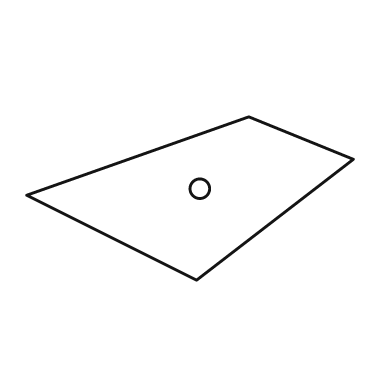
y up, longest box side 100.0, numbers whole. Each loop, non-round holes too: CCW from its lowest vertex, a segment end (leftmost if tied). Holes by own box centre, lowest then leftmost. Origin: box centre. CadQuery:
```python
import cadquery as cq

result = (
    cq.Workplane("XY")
    .moveTo(2.0, -25.0)
    .lineTo(50.0, 12.0)
    .lineTo(18.0, 25.0)
    .lineTo(-50.0, 1.0)
    .close()
    .moveTo(3.0, 3.0)
    .circle(3.0)
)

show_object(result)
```